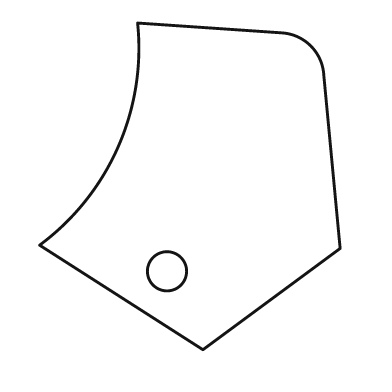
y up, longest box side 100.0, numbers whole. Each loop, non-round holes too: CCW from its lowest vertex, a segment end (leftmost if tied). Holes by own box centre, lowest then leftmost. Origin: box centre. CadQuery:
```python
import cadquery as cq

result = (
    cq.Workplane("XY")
    .moveTo(4.0, -50.0)
    .lineTo(46.0, -19.0)
    .lineTo(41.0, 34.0)
    .threePointArc((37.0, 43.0), (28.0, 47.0))
    .lineTo(-16.0, 50.0)
    .threePointArc((-22.0, 12.0), (-46.0, -18.0))
    .close()
    .moveTo(-7.0, -26.0)
    .circle(6.0)
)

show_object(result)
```